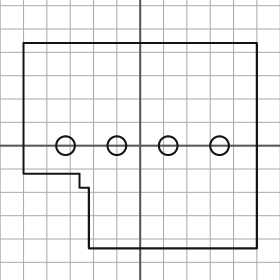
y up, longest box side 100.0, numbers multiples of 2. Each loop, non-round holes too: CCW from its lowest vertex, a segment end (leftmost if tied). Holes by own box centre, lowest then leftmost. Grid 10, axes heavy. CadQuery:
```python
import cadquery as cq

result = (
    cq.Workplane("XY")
    .moveTo(-22.0, -44.0)
    .lineTo(50.0, -44.0)
    .lineTo(50.0, 44.0)
    .lineTo(-50.0, 44.0)
    .lineTo(-50.0, -12.0)
    .lineTo(-26.0, -12.0)
    .lineTo(-26.0, -18.0)
    .lineTo(-22.0, -18.0)
    .close()
    .moveTo(-32.0, 0.0)
    .circle(4.0)
    .moveTo(-10.0, 0.0)
    .circle(4.0)
    .moveTo(12.0, 0.0)
    .circle(4.0)
    .moveTo(34.0, 0.0)
    .circle(4.0)
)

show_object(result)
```